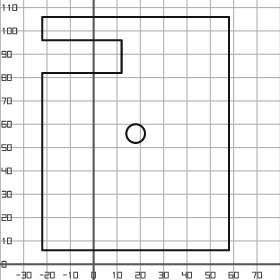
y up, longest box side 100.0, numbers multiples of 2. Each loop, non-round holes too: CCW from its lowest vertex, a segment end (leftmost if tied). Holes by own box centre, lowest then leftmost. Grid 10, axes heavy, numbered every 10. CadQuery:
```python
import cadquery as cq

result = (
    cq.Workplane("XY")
    .moveTo(-22.0, 6.0)
    .lineTo(58.0, 6.0)
    .lineTo(58.0, 106.0)
    .lineTo(-22.0, 106.0)
    .lineTo(-22.0, 96.0)
    .lineTo(12.0, 96.0)
    .lineTo(12.0, 82.0)
    .lineTo(-22.0, 82.0)
    .close()
    .moveTo(18.0, 56.0)
    .circle(4.0)
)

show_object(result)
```